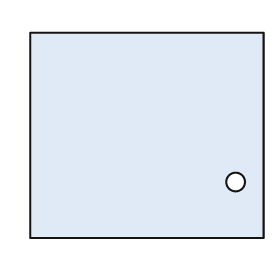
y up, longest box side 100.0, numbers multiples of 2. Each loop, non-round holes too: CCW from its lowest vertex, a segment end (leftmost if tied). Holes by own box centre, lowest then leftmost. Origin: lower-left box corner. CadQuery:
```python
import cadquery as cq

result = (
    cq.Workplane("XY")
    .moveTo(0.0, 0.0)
    .lineTo(100.0, 0.0)
    .lineTo(100.0, 88.0)
    .lineTo(0.0, 88.0)
    .close()
    .moveTo(88.0, 24.0)
    .circle(4.0)
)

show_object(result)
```